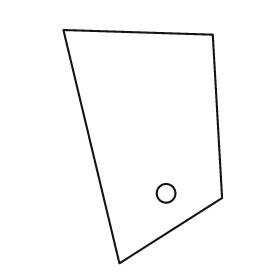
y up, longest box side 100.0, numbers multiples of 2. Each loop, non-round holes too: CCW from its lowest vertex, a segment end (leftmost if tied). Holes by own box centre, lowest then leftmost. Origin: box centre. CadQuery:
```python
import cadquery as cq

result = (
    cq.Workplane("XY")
    .moveTo(-10.0, -50.0)
    .lineTo(34.0, -22.0)
    .lineTo(30.0, 48.0)
    .lineTo(-34.0, 50.0)
    .close()
    .moveTo(10.0, -20.0)
    .circle(4.0)
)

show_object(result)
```